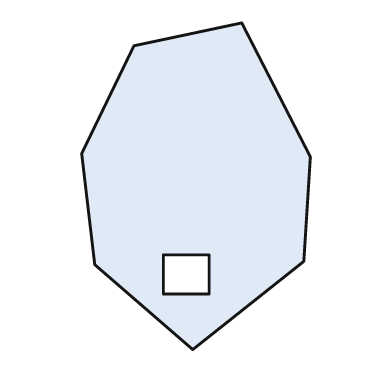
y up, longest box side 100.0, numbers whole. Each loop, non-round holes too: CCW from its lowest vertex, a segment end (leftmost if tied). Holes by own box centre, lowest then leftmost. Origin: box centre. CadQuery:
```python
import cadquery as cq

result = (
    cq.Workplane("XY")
    .moveTo(-1.0, -50.0)
    .lineTo(33.0, -23.0)
    .lineTo(35.0, 9.0)
    .lineTo(14.0, 50.0)
    .lineTo(-19.0, 43.0)
    .lineTo(-35.0, 10.0)
    .lineTo(-31.0, -24.0)
    .close()
    .moveTo(-10.0, -33.0)
    .lineTo(4.0, -33.0)
    .lineTo(4.0, -21.0)
    .lineTo(-10.0, -21.0)
    .close()
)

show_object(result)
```